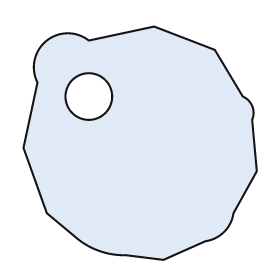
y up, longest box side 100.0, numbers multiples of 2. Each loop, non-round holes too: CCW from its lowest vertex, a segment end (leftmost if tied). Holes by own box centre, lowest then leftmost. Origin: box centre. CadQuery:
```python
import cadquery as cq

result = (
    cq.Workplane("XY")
    .moveTo(10.0, -50.0)
    .lineTo(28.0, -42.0)
    .threePointArc((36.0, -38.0), (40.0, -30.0))
    .lineTo(50.0, -12.0)
    .lineTo(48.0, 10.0)
    .threePointArc((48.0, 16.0), (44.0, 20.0))
    .lineTo(32.0, 40.0)
    .lineTo(6.0, 50.0)
    .lineTo(-22.0, 44.0)
    .threePointArc((-40.0, 44.0), (-44.0, 26.0))
    .lineTo(-50.0, -2.0)
    .lineTo(-40.0, -30.0)
    .lineTo(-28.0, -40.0)
    .threePointArc((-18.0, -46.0), (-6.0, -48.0))
    .close()
    .moveTo(-22.0, 20.0)
    .circle(10.0)
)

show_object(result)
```